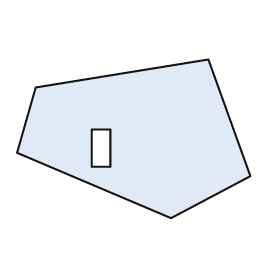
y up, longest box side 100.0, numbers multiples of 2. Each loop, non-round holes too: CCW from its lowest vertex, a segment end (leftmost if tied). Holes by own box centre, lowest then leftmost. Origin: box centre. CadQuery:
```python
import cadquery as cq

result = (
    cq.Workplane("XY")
    .moveTo(16.0, -34.0)
    .lineTo(50.0, -16.0)
    .lineTo(32.0, 34.0)
    .lineTo(-42.0, 22.0)
    .lineTo(-50.0, -6.0)
    .close()
    .moveTo(-18.0, -12.0)
    .lineTo(-10.0, -12.0)
    .lineTo(-10.0, 4.0)
    .lineTo(-18.0, 4.0)
    .close()
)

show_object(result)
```